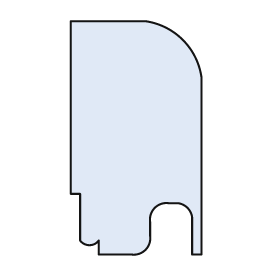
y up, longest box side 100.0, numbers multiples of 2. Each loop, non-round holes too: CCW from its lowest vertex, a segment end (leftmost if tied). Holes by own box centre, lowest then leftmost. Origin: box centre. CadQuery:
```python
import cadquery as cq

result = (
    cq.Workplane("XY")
    .moveTo(-16.0, -50.0)
    .lineTo(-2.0, -50.0)
    .threePointArc((4.0, -48.0), (6.0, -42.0))
    .lineTo(6.0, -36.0)
    .threePointArc((8.0, -30.0), (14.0, -28.0))
    .lineTo(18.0, -28.0)
    .threePointArc((22.0, -30.0), (24.0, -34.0))
    .lineTo(24.0, -50.0)
    .lineTo(28.0, -50.0)
    .lineTo(28.0, 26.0)
    .threePointArc((20.0, 42.0), (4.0, 50.0))
    .lineTo(-28.0, 50.0)
    .lineTo(-28.0, -24.0)
    .lineTo(-24.0, -24.0)
    .lineTo(-24.0, -44.0)
    .threePointArc((-20.0, -46.0), (-16.0, -44.0))
    .close()
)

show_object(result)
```